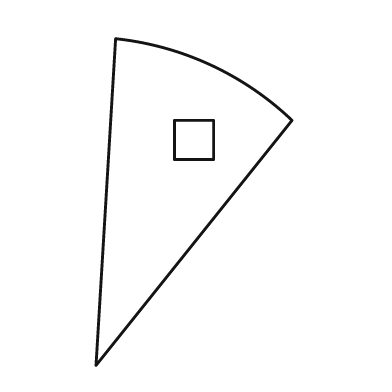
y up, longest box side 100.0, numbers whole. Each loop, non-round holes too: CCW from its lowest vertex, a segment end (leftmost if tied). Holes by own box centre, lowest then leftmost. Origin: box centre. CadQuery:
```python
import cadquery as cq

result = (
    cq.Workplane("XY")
    .moveTo(-30.0, -50.0)
    .lineTo(30.0, 25.0)
    .threePointArc((5.0, 42.0), (-24.0, 50.0))
    .close()
    .moveTo(-6.0, 13.0)
    .lineTo(6.0, 13.0)
    .lineTo(6.0, 25.0)
    .lineTo(-6.0, 25.0)
    .close()
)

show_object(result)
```